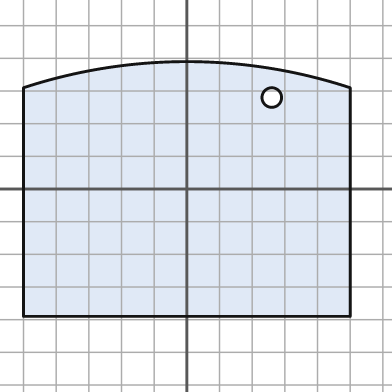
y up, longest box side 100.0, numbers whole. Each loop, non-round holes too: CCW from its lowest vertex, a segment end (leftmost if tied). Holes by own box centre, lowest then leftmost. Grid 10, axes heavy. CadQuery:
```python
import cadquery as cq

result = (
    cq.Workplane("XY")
    .moveTo(-50.0, -39.0)
    .lineTo(50.0, -39.0)
    .lineTo(50.0, 31.0)
    .threePointArc((0.0, 39.0), (-50.0, 31.0))
    .close()
    .moveTo(26.0, 28.0)
    .circle(3.0)
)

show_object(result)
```